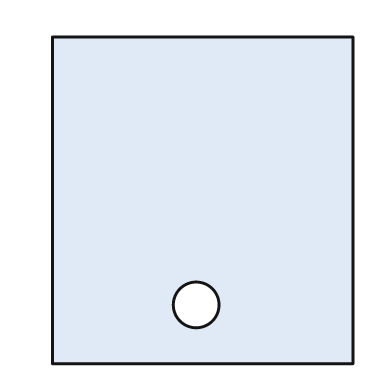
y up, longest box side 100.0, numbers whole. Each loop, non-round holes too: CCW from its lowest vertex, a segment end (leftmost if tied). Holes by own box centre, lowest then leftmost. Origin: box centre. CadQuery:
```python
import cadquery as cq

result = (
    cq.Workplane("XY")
    .moveTo(-46.0, -50.0)
    .lineTo(46.0, -50.0)
    .lineTo(46.0, 50.0)
    .lineTo(-46.0, 50.0)
    .close()
    .moveTo(-2.0, -32.0)
    .circle(7.0)
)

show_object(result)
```